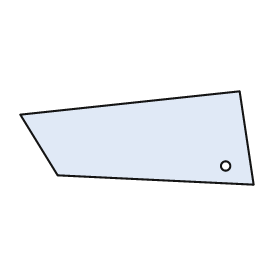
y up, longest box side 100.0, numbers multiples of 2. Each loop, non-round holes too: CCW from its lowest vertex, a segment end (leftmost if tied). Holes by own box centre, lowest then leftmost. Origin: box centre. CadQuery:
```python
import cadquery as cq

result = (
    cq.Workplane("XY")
    .moveTo(50.0, -20.0)
    .lineTo(44.0, 20.0)
    .lineTo(-50.0, 10.0)
    .lineTo(-34.0, -16.0)
    .close()
    .moveTo(38.0, -12.0)
    .circle(2.0)
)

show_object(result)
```